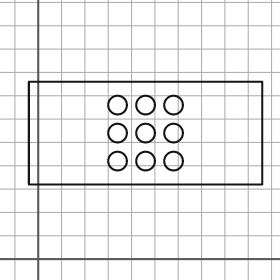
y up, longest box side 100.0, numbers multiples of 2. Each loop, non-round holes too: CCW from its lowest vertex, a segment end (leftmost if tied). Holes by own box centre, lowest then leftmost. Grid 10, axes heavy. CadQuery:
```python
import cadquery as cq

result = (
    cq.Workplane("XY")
    .moveTo(-4.0, 32.0)
    .lineTo(96.0, 32.0)
    .lineTo(96.0, 76.0)
    .lineTo(-4.0, 76.0)
    .close()
    .moveTo(34.0, 42.0)
    .circle(4.0)
    .moveTo(46.0, 42.0)
    .circle(4.0)
    .moveTo(58.0, 42.0)
    .circle(4.0)
    .moveTo(34.0, 54.0)
    .circle(4.0)
    .moveTo(46.0, 54.0)
    .circle(4.0)
    .moveTo(58.0, 54.0)
    .circle(4.0)
    .moveTo(34.0, 66.0)
    .circle(4.0)
    .moveTo(46.0, 66.0)
    .circle(4.0)
    .moveTo(58.0, 66.0)
    .circle(4.0)
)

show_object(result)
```